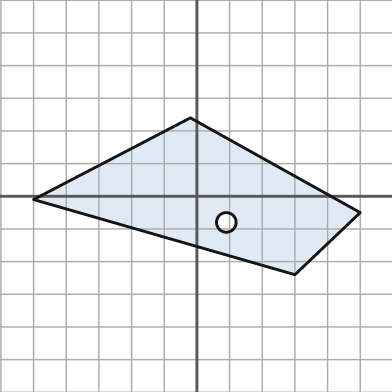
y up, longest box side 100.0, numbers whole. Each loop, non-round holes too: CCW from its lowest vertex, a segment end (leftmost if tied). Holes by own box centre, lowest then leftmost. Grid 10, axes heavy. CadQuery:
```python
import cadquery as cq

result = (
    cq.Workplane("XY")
    .moveTo(30.0, -24.0)
    .lineTo(50.0, -5.0)
    .lineTo(-2.0, 24.0)
    .lineTo(-50.0, -1.0)
    .close()
    .moveTo(9.0, -8.0)
    .circle(3.0)
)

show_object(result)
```